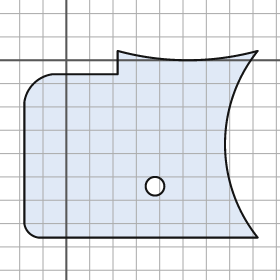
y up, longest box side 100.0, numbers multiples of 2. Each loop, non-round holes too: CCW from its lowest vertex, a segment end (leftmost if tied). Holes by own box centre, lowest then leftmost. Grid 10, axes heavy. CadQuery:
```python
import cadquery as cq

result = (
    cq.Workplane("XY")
    .moveTo(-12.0, -76.0)
    .lineTo(82.0, -76.0)
    .threePointArc((68.0, -36.0), (82.0, 4.0))
    .threePointArc((52.0, 0.0), (22.0, 4.0))
    .lineTo(22.0, -6.0)
    .lineTo(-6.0, -6.0)
    .threePointArc((-14.0, -10.0), (-18.0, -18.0))
    .lineTo(-18.0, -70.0)
    .threePointArc((-16.0, -74.0), (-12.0, -76.0))
    .close()
    .moveTo(38.0, -54.0)
    .circle(4.0)
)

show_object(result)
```